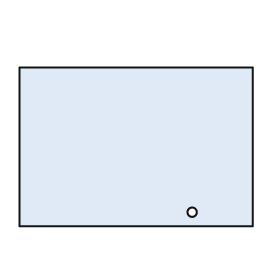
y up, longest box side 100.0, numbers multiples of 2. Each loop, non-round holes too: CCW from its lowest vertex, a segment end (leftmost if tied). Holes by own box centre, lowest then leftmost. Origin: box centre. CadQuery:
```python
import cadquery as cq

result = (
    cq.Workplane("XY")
    .moveTo(-50.0, -34.0)
    .lineTo(50.0, -34.0)
    .lineTo(50.0, 34.0)
    .lineTo(-50.0, 34.0)
    .close()
    .moveTo(24.0, -28.0)
    .circle(2.0)
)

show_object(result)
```